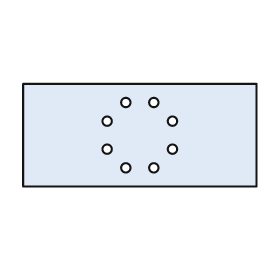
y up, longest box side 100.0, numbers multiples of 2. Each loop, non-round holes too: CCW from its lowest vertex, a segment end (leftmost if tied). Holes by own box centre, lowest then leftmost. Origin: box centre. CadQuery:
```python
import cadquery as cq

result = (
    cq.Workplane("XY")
    .moveTo(-50.0, -22.0)
    .lineTo(50.0, -22.0)
    .lineTo(50.0, 22.0)
    .lineTo(-50.0, 22.0)
    .close()
    .moveTo(-6.0, -14.0)
    .circle(2.0)
    .moveTo(6.0, -14.0)
    .circle(2.0)
    .moveTo(-14.0, -6.0)
    .circle(2.0)
    .moveTo(14.0, -6.0)
    .circle(2.0)
    .moveTo(-14.0, 6.0)
    .circle(2.0)
    .moveTo(14.0, 6.0)
    .circle(2.0)
    .moveTo(-6.0, 14.0)
    .circle(2.0)
    .moveTo(6.0, 14.0)
    .circle(2.0)
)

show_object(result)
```